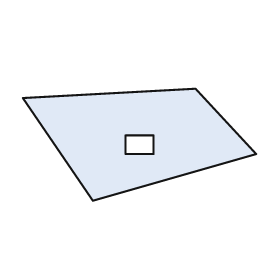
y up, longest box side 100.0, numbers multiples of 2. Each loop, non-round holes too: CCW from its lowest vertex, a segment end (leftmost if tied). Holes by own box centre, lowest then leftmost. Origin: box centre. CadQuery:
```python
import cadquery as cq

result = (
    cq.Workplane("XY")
    .moveTo(-20.0, -24.0)
    .lineTo(50.0, -4.0)
    .lineTo(24.0, 24.0)
    .lineTo(-50.0, 20.0)
    .close()
    .moveTo(-6.0, -4.0)
    .lineTo(6.0, -4.0)
    .lineTo(6.0, 4.0)
    .lineTo(-6.0, 4.0)
    .close()
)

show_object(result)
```